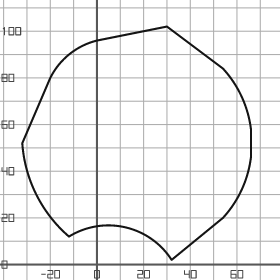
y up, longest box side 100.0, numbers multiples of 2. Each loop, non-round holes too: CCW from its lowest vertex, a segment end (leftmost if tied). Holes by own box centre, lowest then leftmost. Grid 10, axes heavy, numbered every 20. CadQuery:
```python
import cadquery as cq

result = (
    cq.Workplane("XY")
    .moveTo(32.0, 2.0)
    .lineTo(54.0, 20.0)
    .threePointArc((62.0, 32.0), (66.0, 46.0))
    .lineTo(66.0, 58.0)
    .threePointArc((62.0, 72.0), (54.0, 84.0))
    .lineTo(30.0, 102.0)
    .lineTo(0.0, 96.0)
    .threePointArc((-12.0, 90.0), (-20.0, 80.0))
    .lineTo(-32.0, 52.0)
    .threePointArc((-26.0, 30.0), (-12.0, 12.0))
    .threePointArc((12.0, 16.0), (32.0, 2.0))
    .close()
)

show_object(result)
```